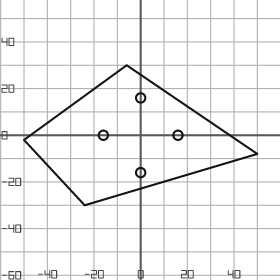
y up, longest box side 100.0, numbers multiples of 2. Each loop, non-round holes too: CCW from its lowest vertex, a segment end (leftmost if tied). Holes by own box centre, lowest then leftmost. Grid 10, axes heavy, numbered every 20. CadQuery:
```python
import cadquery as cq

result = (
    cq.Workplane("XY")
    .moveTo(-24.0, -30.0)
    .lineTo(50.0, -8.0)
    .lineTo(-6.0, 30.0)
    .lineTo(-50.0, -2.0)
    .close()
    .moveTo(0.0, -16.0)
    .circle(2.0)
    .moveTo(-16.0, 0.0)
    .circle(2.0)
    .moveTo(16.0, 0.0)
    .circle(2.0)
    .moveTo(0.0, 16.0)
    .circle(2.0)
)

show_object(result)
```